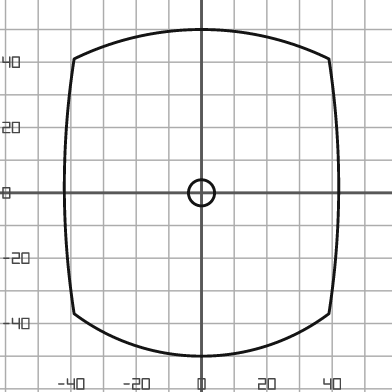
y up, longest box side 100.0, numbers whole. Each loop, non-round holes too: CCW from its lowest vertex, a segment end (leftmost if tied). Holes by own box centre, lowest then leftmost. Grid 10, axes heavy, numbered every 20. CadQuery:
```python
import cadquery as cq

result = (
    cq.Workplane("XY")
    .moveTo(-39.0, -37.0)
    .threePointArc((0.0, -50.0), (39.0, -37.0))
    .threePointArc((42.0, 2.0), (39.0, 41.0))
    .threePointArc((0.0, 50.0), (-39.0, 41.0))
    .threePointArc((-42.0, 2.0), (-39.0, -37.0))
    .close()
    .moveTo(0.0, 0.0)
    .circle(4.0)
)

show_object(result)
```